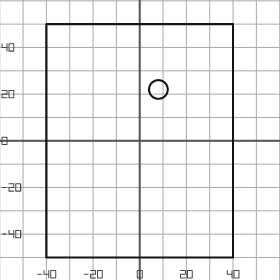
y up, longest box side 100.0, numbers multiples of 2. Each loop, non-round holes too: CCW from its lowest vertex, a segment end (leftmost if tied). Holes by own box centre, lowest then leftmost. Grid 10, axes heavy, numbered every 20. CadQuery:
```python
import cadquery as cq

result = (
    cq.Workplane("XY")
    .moveTo(-40.0, -50.0)
    .lineTo(40.0, -50.0)
    .lineTo(40.0, 50.0)
    .lineTo(-40.0, 50.0)
    .close()
    .moveTo(8.0, 22.0)
    .circle(4.0)
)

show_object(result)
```